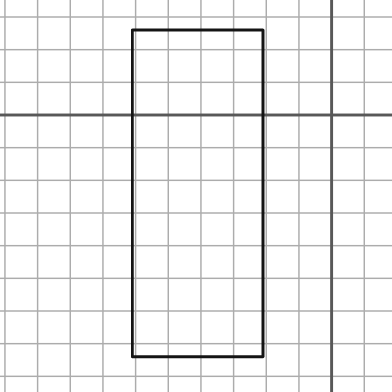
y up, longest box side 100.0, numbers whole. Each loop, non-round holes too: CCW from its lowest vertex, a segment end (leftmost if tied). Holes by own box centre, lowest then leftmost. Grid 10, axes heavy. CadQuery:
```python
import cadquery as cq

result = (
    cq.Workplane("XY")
    .moveTo(-61.0, -74.0)
    .lineTo(-21.0, -74.0)
    .lineTo(-21.0, 26.0)
    .lineTo(-61.0, 26.0)
    .close()
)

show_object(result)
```